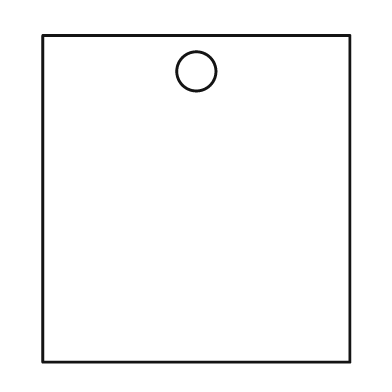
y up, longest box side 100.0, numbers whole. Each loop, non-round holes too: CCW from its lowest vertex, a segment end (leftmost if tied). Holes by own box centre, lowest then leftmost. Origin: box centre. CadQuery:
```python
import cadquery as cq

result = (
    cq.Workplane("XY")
    .moveTo(-47.0, -50.0)
    .lineTo(47.0, -50.0)
    .lineTo(47.0, 50.0)
    .lineTo(-47.0, 50.0)
    .close()
    .moveTo(0.0, 39.0)
    .circle(6.0)
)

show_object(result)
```